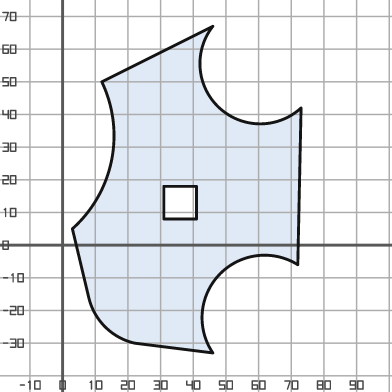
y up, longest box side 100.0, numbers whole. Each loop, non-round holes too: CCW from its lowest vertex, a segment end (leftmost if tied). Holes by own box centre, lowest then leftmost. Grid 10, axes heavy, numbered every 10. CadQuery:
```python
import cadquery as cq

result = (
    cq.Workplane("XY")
    .moveTo(46.0, -33.0)
    .threePointArc((48.0, -9.0), (72.0, -6.0))
    .lineTo(73.0, 42.0)
    .threePointArc((48.0, 42.0), (46.0, 67.0))
    .lineTo(12.0, 50.0)
    .threePointArc((15.0, 26.0), (3.0, 5.0))
    .lineTo(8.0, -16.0)
    .threePointArc((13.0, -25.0), (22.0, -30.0))
    .close()
    .moveTo(31.0, 8.0)
    .lineTo(41.0, 8.0)
    .lineTo(41.0, 18.0)
    .lineTo(31.0, 18.0)
    .close()
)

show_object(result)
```